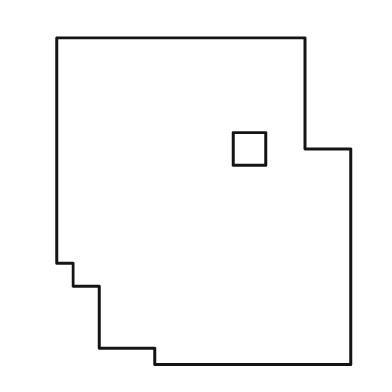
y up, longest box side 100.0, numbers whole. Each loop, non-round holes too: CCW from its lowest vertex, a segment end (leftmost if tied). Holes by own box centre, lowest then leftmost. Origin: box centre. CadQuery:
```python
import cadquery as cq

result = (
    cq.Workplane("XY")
    .moveTo(-15.0, -50.0)
    .lineTo(45.0, -50.0)
    .lineTo(45.0, 16.0)
    .lineTo(31.0, 16.0)
    .lineTo(31.0, 50.0)
    .lineTo(-45.0, 50.0)
    .lineTo(-45.0, -19.0)
    .lineTo(-40.0, -19.0)
    .lineTo(-40.0, -26.0)
    .lineTo(-32.0, -26.0)
    .lineTo(-32.0, -45.0)
    .lineTo(-15.0, -45.0)
    .close()
    .moveTo(9.0, 11.0)
    .lineTo(19.0, 11.0)
    .lineTo(19.0, 21.0)
    .lineTo(9.0, 21.0)
    .close()
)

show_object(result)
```